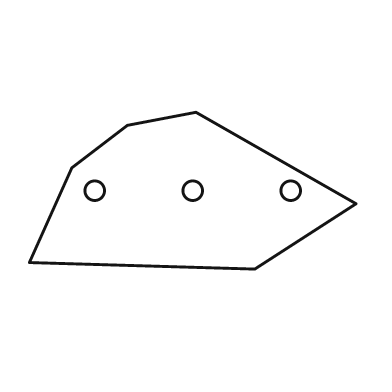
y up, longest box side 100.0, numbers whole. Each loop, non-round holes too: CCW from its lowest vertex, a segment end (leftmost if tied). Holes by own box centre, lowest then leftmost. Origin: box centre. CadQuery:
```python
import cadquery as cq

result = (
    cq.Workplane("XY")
    .moveTo(19.0, -24.0)
    .lineTo(50.0, -4.0)
    .lineTo(1.0, 24.0)
    .lineTo(-20.0, 20.0)
    .lineTo(-37.0, 7.0)
    .lineTo(-50.0, -22.0)
    .close()
    .moveTo(-30.0, 0.0)
    .circle(3.0)
    .moveTo(0.0, 0.0)
    .circle(3.0)
    .moveTo(30.0, 0.0)
    .circle(3.0)
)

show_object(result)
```